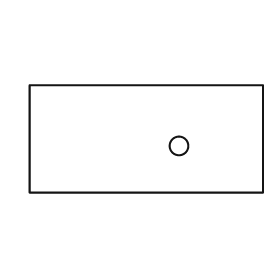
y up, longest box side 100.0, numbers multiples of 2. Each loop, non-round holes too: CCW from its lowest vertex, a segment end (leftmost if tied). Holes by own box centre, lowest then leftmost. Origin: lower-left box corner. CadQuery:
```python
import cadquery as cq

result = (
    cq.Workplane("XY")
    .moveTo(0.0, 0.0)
    .lineTo(100.0, 0.0)
    .lineTo(100.0, 46.0)
    .lineTo(0.0, 46.0)
    .close()
    .moveTo(64.0, 20.0)
    .circle(4.0)
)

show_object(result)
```